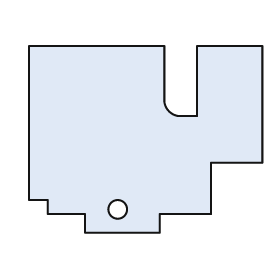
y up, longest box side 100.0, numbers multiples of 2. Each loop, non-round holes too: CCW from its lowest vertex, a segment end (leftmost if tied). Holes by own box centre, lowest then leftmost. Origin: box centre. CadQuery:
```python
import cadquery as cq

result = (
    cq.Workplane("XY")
    .moveTo(-26.0, -40.0)
    .lineTo(6.0, -40.0)
    .lineTo(6.0, -32.0)
    .lineTo(28.0, -32.0)
    .lineTo(28.0, -10.0)
    .lineTo(50.0, -10.0)
    .lineTo(50.0, 40.0)
    .lineTo(22.0, 40.0)
    .lineTo(22.0, 10.0)
    .lineTo(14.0, 10.0)
    .threePointArc((10.0, 12.0), (8.0, 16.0))
    .lineTo(8.0, 40.0)
    .lineTo(-50.0, 40.0)
    .lineTo(-50.0, -26.0)
    .lineTo(-42.0, -26.0)
    .lineTo(-42.0, -32.0)
    .lineTo(-26.0, -32.0)
    .close()
    .moveTo(-12.0, -30.0)
    .circle(4.0)
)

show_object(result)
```